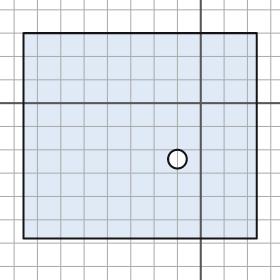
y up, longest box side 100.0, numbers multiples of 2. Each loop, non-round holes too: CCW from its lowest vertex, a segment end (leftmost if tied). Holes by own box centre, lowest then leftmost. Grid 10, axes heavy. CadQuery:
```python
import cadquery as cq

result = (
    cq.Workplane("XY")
    .moveTo(-76.0, -58.0)
    .lineTo(24.0, -58.0)
    .lineTo(24.0, 30.0)
    .lineTo(-76.0, 30.0)
    .close()
    .moveTo(-10.0, -24.0)
    .circle(4.0)
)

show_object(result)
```